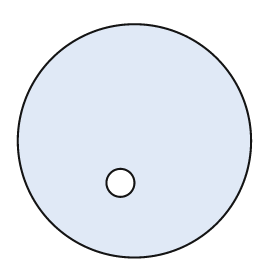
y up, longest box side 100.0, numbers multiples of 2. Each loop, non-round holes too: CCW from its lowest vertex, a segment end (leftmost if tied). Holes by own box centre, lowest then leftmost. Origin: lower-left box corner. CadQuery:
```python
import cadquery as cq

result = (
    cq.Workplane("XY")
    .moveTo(50.0, 50.0)
    .circle(50.0)
    .moveTo(44.0, 32.0)
    .circle(6.0)
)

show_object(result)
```